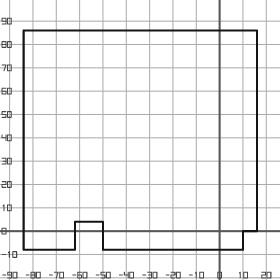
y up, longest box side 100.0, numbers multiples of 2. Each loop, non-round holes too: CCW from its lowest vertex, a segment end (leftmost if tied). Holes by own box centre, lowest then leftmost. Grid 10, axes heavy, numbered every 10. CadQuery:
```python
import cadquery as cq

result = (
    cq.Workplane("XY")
    .moveTo(-84.0, -8.0)
    .lineTo(-62.0, -8.0)
    .lineTo(-62.0, 4.0)
    .lineTo(-50.0, 4.0)
    .lineTo(-50.0, -8.0)
    .lineTo(10.0, -8.0)
    .lineTo(10.0, 0.0)
    .lineTo(16.0, 0.0)
    .lineTo(16.0, 86.0)
    .lineTo(-84.0, 86.0)
    .close()
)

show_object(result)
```